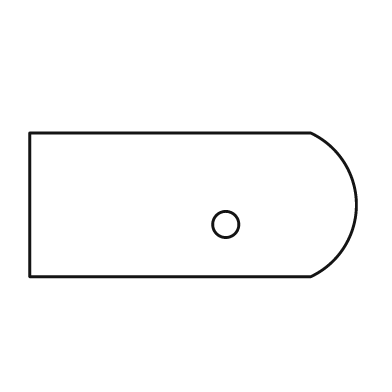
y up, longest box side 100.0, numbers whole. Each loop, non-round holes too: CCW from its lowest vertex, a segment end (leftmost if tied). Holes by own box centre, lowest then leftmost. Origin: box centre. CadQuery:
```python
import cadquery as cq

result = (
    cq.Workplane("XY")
    .moveTo(-50.0, -22.0)
    .lineTo(36.0, -22.0)
    .threePointArc((50.0, 0.0), (36.0, 22.0))
    .lineTo(-50.0, 22.0)
    .close()
    .moveTo(10.0, -6.0)
    .circle(4.0)
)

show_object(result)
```